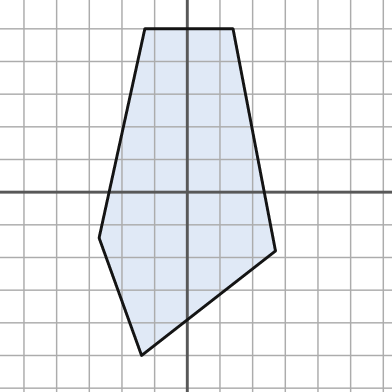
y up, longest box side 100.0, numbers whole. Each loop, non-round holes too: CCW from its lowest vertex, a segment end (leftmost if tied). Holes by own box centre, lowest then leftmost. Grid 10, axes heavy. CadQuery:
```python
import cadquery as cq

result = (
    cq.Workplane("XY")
    .moveTo(-14.0, -50.0)
    .lineTo(27.0, -18.0)
    .lineTo(14.0, 50.0)
    .lineTo(-13.0, 50.0)
    .lineTo(-27.0, -14.0)
    .close()
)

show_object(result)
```